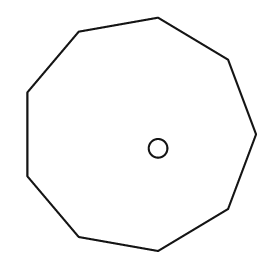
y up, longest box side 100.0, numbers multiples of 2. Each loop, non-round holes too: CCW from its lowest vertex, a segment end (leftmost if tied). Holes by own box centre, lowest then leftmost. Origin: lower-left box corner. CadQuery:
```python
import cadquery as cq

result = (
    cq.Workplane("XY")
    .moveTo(56.0, 0.0)
    .lineTo(86.0, 18.0)
    .lineTo(98.0, 50.0)
    .lineTo(86.0, 82.0)
    .lineTo(56.0, 100.0)
    .lineTo(22.0, 94.0)
    .lineTo(0.0, 68.0)
    .lineTo(0.0, 32.0)
    .lineTo(22.0, 6.0)
    .close()
    .moveTo(56.0, 44.0)
    .circle(4.0)
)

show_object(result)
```